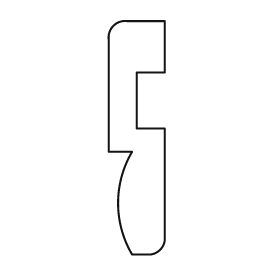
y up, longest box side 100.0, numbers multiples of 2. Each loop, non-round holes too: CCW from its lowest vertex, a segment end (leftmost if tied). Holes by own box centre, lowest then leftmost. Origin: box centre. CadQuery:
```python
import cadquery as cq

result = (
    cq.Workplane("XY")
    .moveTo(-2.0, -50.0)
    .lineTo(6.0, -50.0)
    .threePointArc((10.0, -48.0), (12.0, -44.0))
    .lineTo(12.0, 4.0)
    .lineTo(0.0, 4.0)
    .lineTo(0.0, 28.0)
    .lineTo(12.0, 28.0)
    .lineTo(12.0, 50.0)
    .lineTo(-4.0, 50.0)
    .threePointArc((-10.0, 48.0), (-12.0, 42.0))
    .lineTo(-12.0, -6.0)
    .lineTo(-2.0, -6.0)
    .threePointArc((-8.0, -28.0), (-2.0, -50.0))
    .close()
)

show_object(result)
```